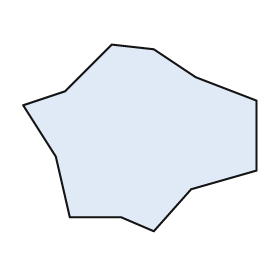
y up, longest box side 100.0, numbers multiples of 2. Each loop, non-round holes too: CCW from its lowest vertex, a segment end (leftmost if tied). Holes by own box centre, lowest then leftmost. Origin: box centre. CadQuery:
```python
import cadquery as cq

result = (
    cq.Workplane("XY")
    .moveTo(6.0, -40.0)
    .lineTo(22.0, -22.0)
    .lineTo(50.0, -14.0)
    .lineTo(50.0, 16.0)
    .lineTo(24.0, 26.0)
    .lineTo(6.0, 38.0)
    .lineTo(-12.0, 40.0)
    .lineTo(-32.0, 20.0)
    .lineTo(-50.0, 14.0)
    .lineTo(-36.0, -8.0)
    .lineTo(-30.0, -34.0)
    .lineTo(-8.0, -34.0)
    .close()
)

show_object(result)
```